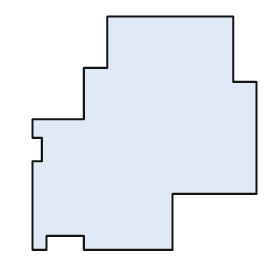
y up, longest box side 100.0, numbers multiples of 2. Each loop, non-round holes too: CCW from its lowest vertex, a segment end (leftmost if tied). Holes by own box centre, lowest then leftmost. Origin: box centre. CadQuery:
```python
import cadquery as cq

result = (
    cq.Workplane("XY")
    .moveTo(-48.0, -50.0)
    .lineTo(-42.0, -50.0)
    .lineTo(-42.0, -44.0)
    .lineTo(-26.0, -44.0)
    .lineTo(-26.0, -50.0)
    .lineTo(12.0, -50.0)
    .lineTo(12.0, -26.0)
    .lineTo(48.0, -26.0)
    .lineTo(48.0, 22.0)
    .lineTo(38.0, 22.0)
    .lineTo(38.0, 50.0)
    .lineTo(-16.0, 50.0)
    .lineTo(-16.0, 28.0)
    .lineTo(-26.0, 28.0)
    .lineTo(-26.0, 6.0)
    .lineTo(-48.0, 6.0)
    .lineTo(-48.0, -2.0)
    .lineTo(-44.0, -2.0)
    .lineTo(-44.0, -12.0)
    .lineTo(-48.0, -12.0)
    .close()
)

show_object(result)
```